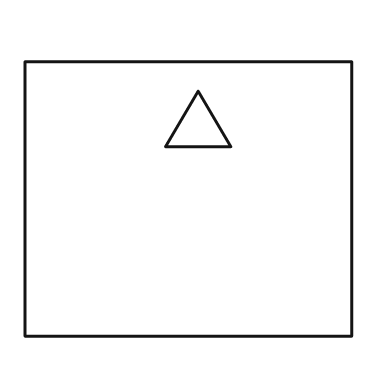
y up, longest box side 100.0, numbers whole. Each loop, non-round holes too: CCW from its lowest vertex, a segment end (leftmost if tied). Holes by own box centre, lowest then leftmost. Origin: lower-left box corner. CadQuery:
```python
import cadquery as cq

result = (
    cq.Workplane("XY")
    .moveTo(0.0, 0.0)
    .lineTo(100.0, 0.0)
    .lineTo(100.0, 84.0)
    .lineTo(0.0, 84.0)
    .close()
    .moveTo(43.0, 58.0)
    .lineTo(63.0, 58.0)
    .lineTo(53.0, 75.0)
    .close()
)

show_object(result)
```